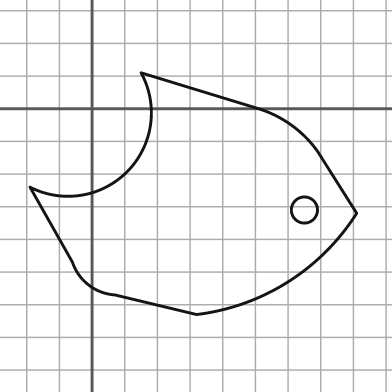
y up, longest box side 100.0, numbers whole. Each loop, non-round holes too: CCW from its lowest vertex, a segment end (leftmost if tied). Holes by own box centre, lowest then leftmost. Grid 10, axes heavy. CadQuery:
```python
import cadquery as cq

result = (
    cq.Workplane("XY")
    .moveTo(32.0, -63.0)
    .threePointArc((60.0, -53.0), (81.0, -32.0))
    .lineTo(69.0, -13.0)
    .threePointArc((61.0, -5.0), (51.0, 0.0))
    .lineTo(15.0, 11.0)
    .threePointArc((11.0, -19.0), (-19.0, -24.0))
    .lineTo(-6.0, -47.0)
    .threePointArc((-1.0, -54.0), (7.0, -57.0))
    .close()
    .moveTo(65.0, -31.0)
    .circle(4.0)
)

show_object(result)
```